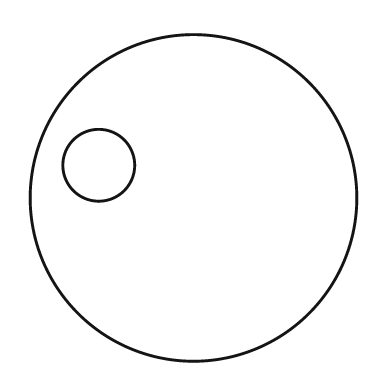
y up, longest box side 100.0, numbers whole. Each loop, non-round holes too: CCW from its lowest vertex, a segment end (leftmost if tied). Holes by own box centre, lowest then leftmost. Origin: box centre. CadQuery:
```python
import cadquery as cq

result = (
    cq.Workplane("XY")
    .moveTo(0.0, 0.0)
    .circle(50.0)
    .moveTo(-29.0, 10.0)
    .circle(11.0)
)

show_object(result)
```